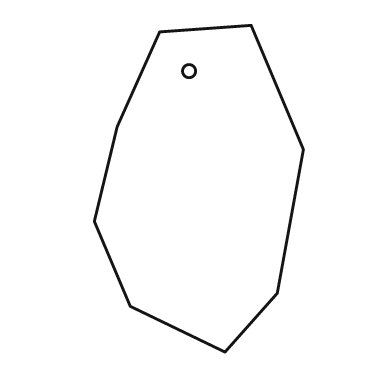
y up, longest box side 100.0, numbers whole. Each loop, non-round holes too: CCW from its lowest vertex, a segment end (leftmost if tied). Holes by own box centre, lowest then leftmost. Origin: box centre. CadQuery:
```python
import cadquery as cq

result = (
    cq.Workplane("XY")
    .moveTo(8.0, -50.0)
    .lineTo(24.0, -32.0)
    .lineTo(32.0, 12.0)
    .lineTo(16.0, 50.0)
    .lineTo(-12.0, 48.0)
    .lineTo(-25.0, 19.0)
    .lineTo(-32.0, -10.0)
    .lineTo(-21.0, -36.0)
    .close()
    .moveTo(-3.0, 36.0)
    .circle(2.0)
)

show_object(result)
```